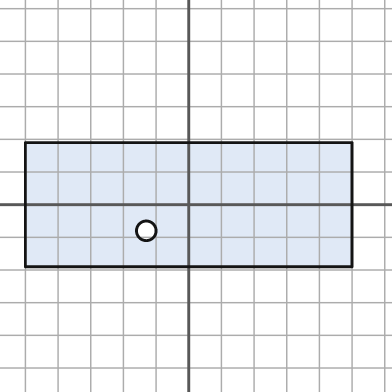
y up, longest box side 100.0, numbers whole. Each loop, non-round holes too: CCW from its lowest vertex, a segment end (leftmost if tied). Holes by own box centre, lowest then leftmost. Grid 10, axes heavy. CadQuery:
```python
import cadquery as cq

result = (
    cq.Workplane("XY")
    .moveTo(-50.0, -19.0)
    .lineTo(50.0, -19.0)
    .lineTo(50.0, 19.0)
    .lineTo(-50.0, 19.0)
    .close()
    .moveTo(-13.0, -8.0)
    .circle(3.0)
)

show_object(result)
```